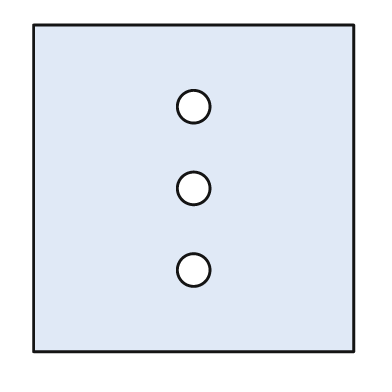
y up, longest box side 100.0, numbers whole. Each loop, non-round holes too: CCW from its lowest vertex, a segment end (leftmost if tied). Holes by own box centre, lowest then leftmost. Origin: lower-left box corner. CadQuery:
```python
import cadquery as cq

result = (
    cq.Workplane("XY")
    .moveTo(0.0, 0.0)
    .lineTo(98.0, 0.0)
    .lineTo(98.0, 100.0)
    .lineTo(0.0, 100.0)
    .close()
    .moveTo(49.0, 25.0)
    .circle(5.0)
    .moveTo(49.0, 50.0)
    .circle(5.0)
    .moveTo(49.0, 75.0)
    .circle(5.0)
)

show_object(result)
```